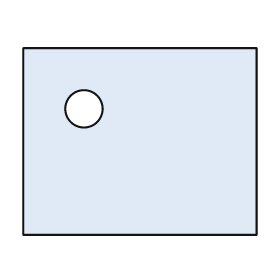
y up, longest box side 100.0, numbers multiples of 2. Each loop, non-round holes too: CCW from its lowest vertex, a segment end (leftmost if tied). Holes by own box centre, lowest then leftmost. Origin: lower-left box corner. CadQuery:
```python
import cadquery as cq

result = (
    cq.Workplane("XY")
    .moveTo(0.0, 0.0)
    .lineTo(100.0, 0.0)
    .lineTo(100.0, 80.0)
    .lineTo(0.0, 80.0)
    .close()
    .moveTo(26.0, 54.0)
    .circle(8.0)
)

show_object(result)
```